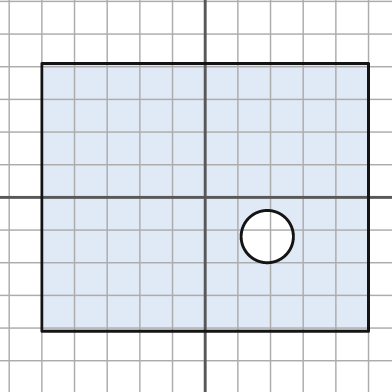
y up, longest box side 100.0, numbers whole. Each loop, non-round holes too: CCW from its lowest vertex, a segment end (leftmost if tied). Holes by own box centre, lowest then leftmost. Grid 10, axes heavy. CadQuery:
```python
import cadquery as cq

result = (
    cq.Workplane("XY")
    .moveTo(-50.0, -41.0)
    .lineTo(50.0, -41.0)
    .lineTo(50.0, 41.0)
    .lineTo(-50.0, 41.0)
    .close()
    .moveTo(19.0, -12.0)
    .circle(8.0)
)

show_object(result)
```